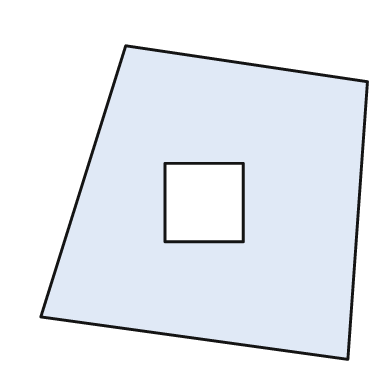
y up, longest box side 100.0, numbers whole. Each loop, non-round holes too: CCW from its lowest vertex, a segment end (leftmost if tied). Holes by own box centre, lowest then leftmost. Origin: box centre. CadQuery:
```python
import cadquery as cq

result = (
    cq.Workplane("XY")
    .moveTo(44.0, -48.0)
    .lineTo(50.0, 37.0)
    .lineTo(-24.0, 48.0)
    .lineTo(-50.0, -35.0)
    .close()
    .moveTo(-12.0, -12.0)
    .lineTo(12.0, -12.0)
    .lineTo(12.0, 12.0)
    .lineTo(-12.0, 12.0)
    .close()
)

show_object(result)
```